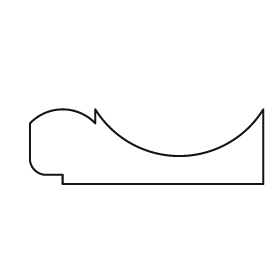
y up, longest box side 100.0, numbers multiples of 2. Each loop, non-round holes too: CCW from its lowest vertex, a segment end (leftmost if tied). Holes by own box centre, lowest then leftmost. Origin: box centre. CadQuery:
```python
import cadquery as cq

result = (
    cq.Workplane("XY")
    .moveTo(-36.0, -16.0)
    .lineTo(50.0, -16.0)
    .lineTo(50.0, 16.0)
    .threePointArc((14.0, -4.0), (-22.0, 16.0))
    .lineTo(-22.0, 10.0)
    .threePointArc((-36.0, 16.0), (-50.0, 10.0))
    .lineTo(-50.0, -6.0)
    .threePointArc((-48.0, -10.0), (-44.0, -12.0))
    .lineTo(-36.0, -12.0)
    .close()
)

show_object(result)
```